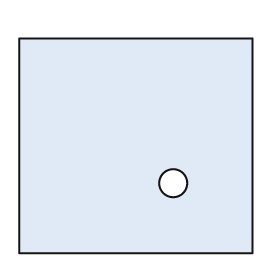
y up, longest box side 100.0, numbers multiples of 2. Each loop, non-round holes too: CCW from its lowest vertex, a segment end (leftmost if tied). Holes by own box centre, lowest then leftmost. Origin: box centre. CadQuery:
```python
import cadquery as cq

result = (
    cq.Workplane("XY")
    .moveTo(-50.0, -46.0)
    .lineTo(50.0, -46.0)
    .lineTo(50.0, 46.0)
    .lineTo(-50.0, 46.0)
    .close()
    .moveTo(16.0, -16.0)
    .circle(6.0)
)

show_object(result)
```